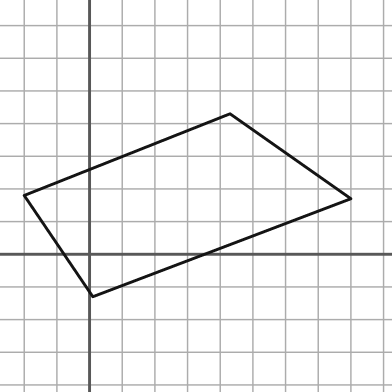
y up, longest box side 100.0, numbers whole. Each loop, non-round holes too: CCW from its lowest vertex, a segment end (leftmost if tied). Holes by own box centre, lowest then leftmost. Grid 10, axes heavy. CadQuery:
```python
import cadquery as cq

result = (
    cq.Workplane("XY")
    .moveTo(1.0, -13.0)
    .lineTo(80.0, 17.0)
    .lineTo(43.0, 43.0)
    .lineTo(-20.0, 18.0)
    .close()
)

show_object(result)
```